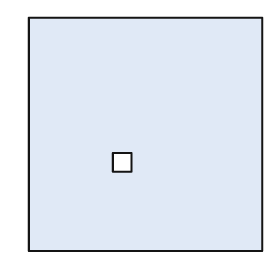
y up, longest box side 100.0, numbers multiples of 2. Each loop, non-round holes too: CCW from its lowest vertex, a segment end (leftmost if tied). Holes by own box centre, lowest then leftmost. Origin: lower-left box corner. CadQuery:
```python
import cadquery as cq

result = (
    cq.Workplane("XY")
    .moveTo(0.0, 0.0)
    .lineTo(100.0, 0.0)
    .lineTo(100.0, 100.0)
    .lineTo(0.0, 100.0)
    .close()
    .moveTo(36.0, 34.0)
    .lineTo(44.0, 34.0)
    .lineTo(44.0, 42.0)
    .lineTo(36.0, 42.0)
    .close()
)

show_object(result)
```